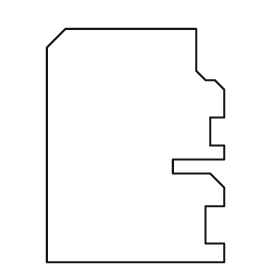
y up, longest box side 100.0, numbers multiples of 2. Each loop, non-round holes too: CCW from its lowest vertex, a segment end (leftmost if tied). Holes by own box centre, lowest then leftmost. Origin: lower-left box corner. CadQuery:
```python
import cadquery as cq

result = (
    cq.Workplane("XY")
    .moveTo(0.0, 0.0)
    .lineTo(76.0, 0.0)
    .lineTo(76.0, 8.0)
    .lineTo(68.0, 8.0)
    .lineTo(68.0, 24.0)
    .lineTo(76.0, 24.0)
    .lineTo(76.0, 32.0)
    .lineTo(70.0, 38.0)
    .lineTo(54.0, 38.0)
    .lineTo(54.0, 44.0)
    .lineTo(76.0, 44.0)
    .lineTo(76.0, 50.0)
    .lineTo(70.0, 50.0)
    .lineTo(70.0, 62.0)
    .lineTo(76.0, 62.0)
    .lineTo(76.0, 74.0)
    .lineTo(72.0, 78.0)
    .lineTo(68.0, 78.0)
    .lineTo(64.0, 82.0)
    .lineTo(64.0, 100.0)
    .lineTo(8.0, 100.0)
    .lineTo(0.0, 92.0)
    .close()
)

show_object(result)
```